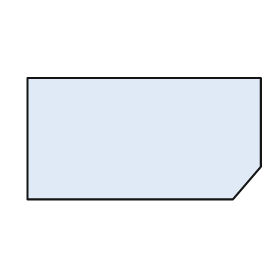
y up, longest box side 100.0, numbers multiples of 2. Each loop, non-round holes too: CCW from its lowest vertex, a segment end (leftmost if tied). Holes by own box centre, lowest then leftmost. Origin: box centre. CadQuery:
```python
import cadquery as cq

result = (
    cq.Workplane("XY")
    .moveTo(-50.0, -26.0)
    .lineTo(38.0, -26.0)
    .lineTo(50.0, -12.0)
    .lineTo(50.0, 26.0)
    .lineTo(-50.0, 26.0)
    .close()
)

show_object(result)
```